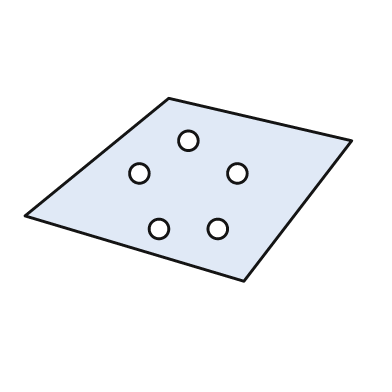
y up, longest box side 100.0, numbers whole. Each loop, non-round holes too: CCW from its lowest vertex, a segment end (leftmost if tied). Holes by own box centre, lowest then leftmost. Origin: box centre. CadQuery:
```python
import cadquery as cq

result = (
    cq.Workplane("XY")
    .moveTo(17.0, -28.0)
    .lineTo(50.0, 15.0)
    .lineTo(-6.0, 28.0)
    .lineTo(-50.0, -8.0)
    .close()
    .moveTo(-9.0, -12.0)
    .circle(3.0)
    .moveTo(9.0, -12.0)
    .circle(3.0)
    .moveTo(-15.0, 5.0)
    .circle(3.0)
    .moveTo(15.0, 5.0)
    .circle(3.0)
    .moveTo(0.0, 15.0)
    .circle(3.0)
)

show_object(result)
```